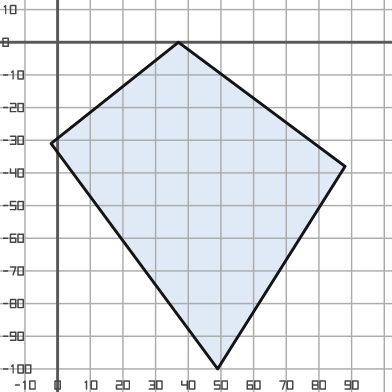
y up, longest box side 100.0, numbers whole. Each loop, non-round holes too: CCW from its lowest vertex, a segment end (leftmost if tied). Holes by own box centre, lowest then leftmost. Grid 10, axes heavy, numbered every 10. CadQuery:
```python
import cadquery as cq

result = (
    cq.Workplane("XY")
    .moveTo(49.0, -100.0)
    .lineTo(88.0, -38.0)
    .lineTo(37.0, 0.0)
    .lineTo(-2.0, -31.0)
    .close()
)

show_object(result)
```